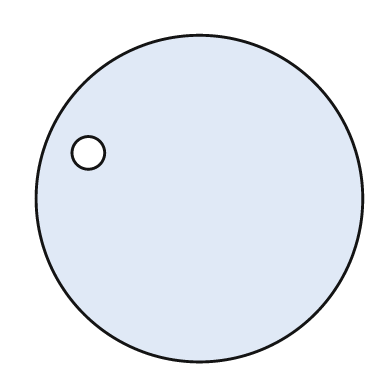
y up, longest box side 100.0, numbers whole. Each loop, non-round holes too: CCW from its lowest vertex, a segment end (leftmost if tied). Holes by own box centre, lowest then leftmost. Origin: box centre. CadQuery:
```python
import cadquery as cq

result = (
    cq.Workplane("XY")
    .moveTo(0.0, 0.0)
    .circle(50.0)
    .moveTo(-34.0, 14.0)
    .circle(5.0)
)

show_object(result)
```